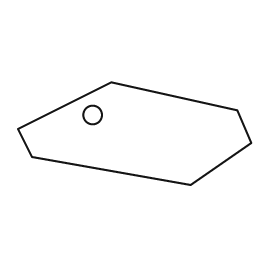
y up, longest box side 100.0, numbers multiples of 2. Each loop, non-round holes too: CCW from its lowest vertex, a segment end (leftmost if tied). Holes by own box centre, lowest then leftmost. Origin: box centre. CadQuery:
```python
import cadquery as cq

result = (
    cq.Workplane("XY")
    .moveTo(24.0, -22.0)
    .lineTo(50.0, -4.0)
    .lineTo(44.0, 10.0)
    .lineTo(-10.0, 22.0)
    .lineTo(-50.0, 2.0)
    .lineTo(-44.0, -10.0)
    .close()
    .moveTo(-18.0, 8.0)
    .circle(4.0)
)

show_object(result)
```